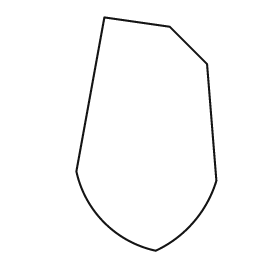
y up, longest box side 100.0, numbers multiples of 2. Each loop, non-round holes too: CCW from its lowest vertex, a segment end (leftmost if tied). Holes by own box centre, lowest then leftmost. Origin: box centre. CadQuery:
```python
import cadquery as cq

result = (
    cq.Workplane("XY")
    .moveTo(4.0, -50.0)
    .threePointArc((20.0, -38.0), (30.0, -20.0))
    .lineTo(26.0, 30.0)
    .lineTo(10.0, 46.0)
    .lineTo(-18.0, 50.0)
    .lineTo(-30.0, -16.0)
    .threePointArc((-18.0, -38.0), (4.0, -50.0))
    .close()
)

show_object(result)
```